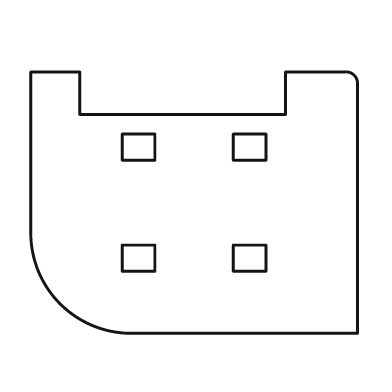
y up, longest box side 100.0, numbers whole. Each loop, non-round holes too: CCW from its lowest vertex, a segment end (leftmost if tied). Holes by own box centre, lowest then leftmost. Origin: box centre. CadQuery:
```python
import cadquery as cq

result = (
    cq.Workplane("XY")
    .moveTo(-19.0, -40.0)
    .lineTo(50.0, -40.0)
    .lineTo(50.0, 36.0)
    .threePointArc((49.0, 39.0), (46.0, 40.0))
    .lineTo(28.0, 40.0)
    .lineTo(28.0, 27.0)
    .lineTo(-35.0, 27.0)
    .lineTo(-35.0, 40.0)
    .lineTo(-50.0, 40.0)
    .lineTo(-50.0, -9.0)
    .threePointArc((-41.0, -31.0), (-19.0, -40.0))
    .close()
    .moveTo(-22.0, -21.0)
    .lineTo(-12.0, -21.0)
    .lineTo(-12.0, -13.0)
    .lineTo(-22.0, -13.0)
    .close()
    .moveTo(12.0, -21.0)
    .lineTo(22.0, -21.0)
    .lineTo(22.0, -13.0)
    .lineTo(12.0, -13.0)
    .close()
    .moveTo(-22.0, 13.0)
    .lineTo(-12.0, 13.0)
    .lineTo(-12.0, 21.0)
    .lineTo(-22.0, 21.0)
    .close()
    .moveTo(12.0, 13.0)
    .lineTo(22.0, 13.0)
    .lineTo(22.0, 21.0)
    .lineTo(12.0, 21.0)
    .close()
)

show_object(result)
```